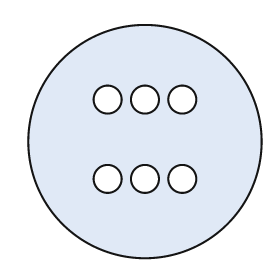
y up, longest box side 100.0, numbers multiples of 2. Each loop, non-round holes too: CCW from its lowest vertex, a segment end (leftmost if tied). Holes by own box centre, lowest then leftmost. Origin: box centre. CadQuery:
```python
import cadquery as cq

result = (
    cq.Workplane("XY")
    .moveTo(0.0, 0.0)
    .circle(50.0)
    .moveTo(-16.0, -16.0)
    .circle(6.0)
    .moveTo(0.0, -16.0)
    .circle(6.0)
    .moveTo(16.0, -16.0)
    .circle(6.0)
    .moveTo(-16.0, 18.0)
    .circle(6.0)
    .moveTo(0.0, 18.0)
    .circle(6.0)
    .moveTo(16.0, 18.0)
    .circle(6.0)
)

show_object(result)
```